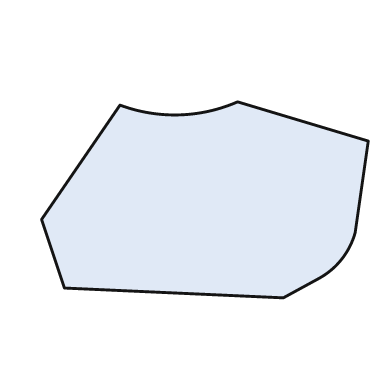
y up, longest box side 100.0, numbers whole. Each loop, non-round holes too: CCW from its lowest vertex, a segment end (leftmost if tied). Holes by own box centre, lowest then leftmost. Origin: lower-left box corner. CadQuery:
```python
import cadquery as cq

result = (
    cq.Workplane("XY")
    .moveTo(74.0, 0.0)
    .lineTo(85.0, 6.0)
    .threePointArc((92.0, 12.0), (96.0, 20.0))
    .lineTo(100.0, 48.0)
    .lineTo(60.0, 60.0)
    .threePointArc((42.0, 56.0), (24.0, 59.0))
    .lineTo(0.0, 24.0)
    .lineTo(7.0, 3.0)
    .close()
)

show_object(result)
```